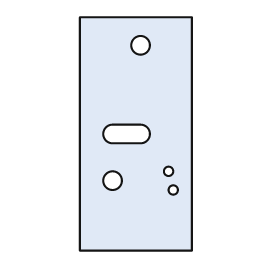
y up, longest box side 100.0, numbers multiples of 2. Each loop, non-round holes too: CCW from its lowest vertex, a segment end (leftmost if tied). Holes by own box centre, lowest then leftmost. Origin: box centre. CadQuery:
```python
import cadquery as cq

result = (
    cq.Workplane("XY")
    .moveTo(-24.0, -50.0)
    .lineTo(24.0, -50.0)
    .lineTo(24.0, 50.0)
    .lineTo(-24.0, 50.0)
    .close()
    .moveTo(16.0, -24.0)
    .circle(2.0)
    .moveTo(-10.0, -20.0)
    .circle(4.0)
    .moveTo(14.0, -16.0)
    .circle(2.0)
    .moveTo(-10.0, -4.0)
    .lineTo(2.0, -4.0)
    .threePointArc((6.0, 0.0), (2.0, 4.0))
    .lineTo(-10.0, 4.0)
    .threePointArc((-14.0, 0.0), (-10.0, -4.0))
    .close()
    .moveTo(2.0, 38.0)
    .circle(4.0)
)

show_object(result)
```